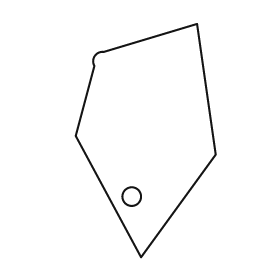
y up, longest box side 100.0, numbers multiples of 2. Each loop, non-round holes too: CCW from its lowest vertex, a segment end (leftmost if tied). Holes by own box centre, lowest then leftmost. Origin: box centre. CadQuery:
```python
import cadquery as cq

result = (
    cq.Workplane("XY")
    .moveTo(-2.0, -50.0)
    .lineTo(30.0, -6.0)
    .lineTo(22.0, 50.0)
    .lineTo(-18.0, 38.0)
    .threePointArc((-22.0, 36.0), (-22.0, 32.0))
    .lineTo(-30.0, 2.0)
    .close()
    .moveTo(-6.0, -24.0)
    .circle(4.0)
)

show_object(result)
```